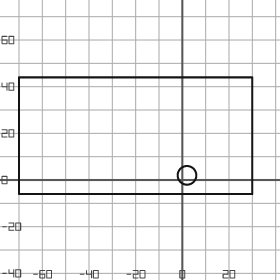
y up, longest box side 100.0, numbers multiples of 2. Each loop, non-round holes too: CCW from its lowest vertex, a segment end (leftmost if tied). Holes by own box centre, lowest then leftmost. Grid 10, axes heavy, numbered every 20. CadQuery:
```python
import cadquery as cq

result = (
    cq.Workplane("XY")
    .moveTo(-70.0, -6.0)
    .lineTo(30.0, -6.0)
    .lineTo(30.0, 44.0)
    .lineTo(-70.0, 44.0)
    .close()
    .moveTo(2.0, 2.0)
    .circle(4.0)
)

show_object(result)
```